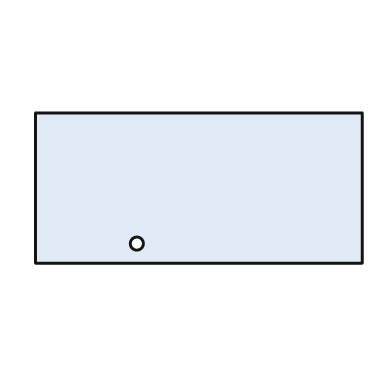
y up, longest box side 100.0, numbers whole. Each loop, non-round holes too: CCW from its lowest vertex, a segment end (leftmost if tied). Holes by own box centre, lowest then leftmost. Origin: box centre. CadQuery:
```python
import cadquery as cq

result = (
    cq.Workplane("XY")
    .moveTo(-50.0, -23.0)
    .lineTo(50.0, -23.0)
    .lineTo(50.0, 23.0)
    .lineTo(-50.0, 23.0)
    .close()
    .moveTo(-19.0, -17.0)
    .circle(2.0)
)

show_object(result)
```